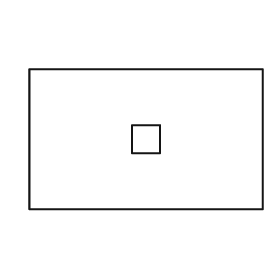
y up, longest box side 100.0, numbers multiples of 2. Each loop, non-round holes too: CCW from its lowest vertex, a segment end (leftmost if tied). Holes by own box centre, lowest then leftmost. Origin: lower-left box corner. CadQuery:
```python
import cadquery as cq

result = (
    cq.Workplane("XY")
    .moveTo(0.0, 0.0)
    .lineTo(100.0, 0.0)
    .lineTo(100.0, 60.0)
    .lineTo(0.0, 60.0)
    .close()
    .moveTo(44.0, 24.0)
    .lineTo(56.0, 24.0)
    .lineTo(56.0, 36.0)
    .lineTo(44.0, 36.0)
    .close()
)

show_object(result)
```